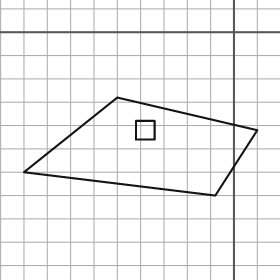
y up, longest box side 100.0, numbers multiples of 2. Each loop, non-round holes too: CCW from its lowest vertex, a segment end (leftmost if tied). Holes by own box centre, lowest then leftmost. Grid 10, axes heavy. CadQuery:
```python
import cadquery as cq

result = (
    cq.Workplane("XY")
    .moveTo(-8.0, -70.0)
    .lineTo(10.0, -42.0)
    .lineTo(-50.0, -28.0)
    .lineTo(-90.0, -60.0)
    .close()
    .moveTo(-42.0, -46.0)
    .lineTo(-34.0, -46.0)
    .lineTo(-34.0, -38.0)
    .lineTo(-42.0, -38.0)
    .close()
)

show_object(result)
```